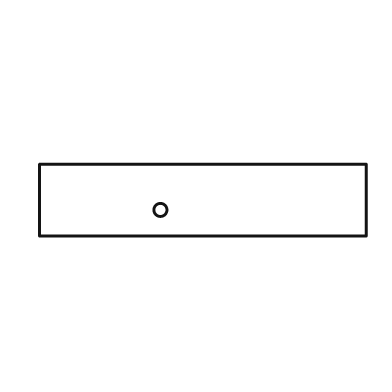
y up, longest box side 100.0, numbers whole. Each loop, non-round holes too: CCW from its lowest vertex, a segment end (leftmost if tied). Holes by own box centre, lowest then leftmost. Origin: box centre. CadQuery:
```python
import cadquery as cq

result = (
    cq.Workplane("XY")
    .moveTo(-50.0, -11.0)
    .lineTo(50.0, -11.0)
    .lineTo(50.0, 11.0)
    .lineTo(-50.0, 11.0)
    .close()
    .moveTo(-13.0, -3.0)
    .circle(2.0)
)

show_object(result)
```